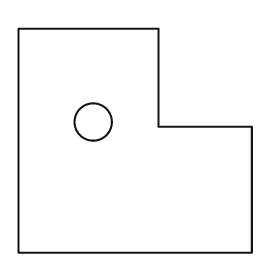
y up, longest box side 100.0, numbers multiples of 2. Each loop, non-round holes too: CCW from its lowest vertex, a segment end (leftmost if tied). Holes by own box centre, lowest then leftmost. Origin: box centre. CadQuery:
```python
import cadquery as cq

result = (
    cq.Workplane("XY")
    .moveTo(-50.0, -48.0)
    .lineTo(50.0, -48.0)
    .lineTo(50.0, 6.0)
    .lineTo(10.0, 6.0)
    .lineTo(10.0, 48.0)
    .lineTo(-50.0, 48.0)
    .close()
    .moveTo(-18.0, 8.0)
    .circle(8.0)
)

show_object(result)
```